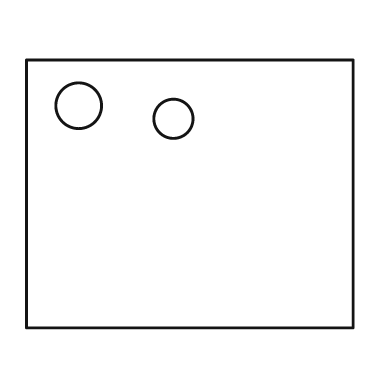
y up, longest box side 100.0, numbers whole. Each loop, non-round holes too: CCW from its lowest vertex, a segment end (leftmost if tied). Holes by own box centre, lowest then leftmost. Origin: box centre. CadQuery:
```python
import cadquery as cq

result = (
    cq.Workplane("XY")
    .moveTo(-50.0, -41.0)
    .lineTo(50.0, -41.0)
    .lineTo(50.0, 41.0)
    .lineTo(-50.0, 41.0)
    .close()
    .moveTo(-5.0, 23.0)
    .circle(6.0)
    .moveTo(-34.0, 27.0)
    .circle(7.0)
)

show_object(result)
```